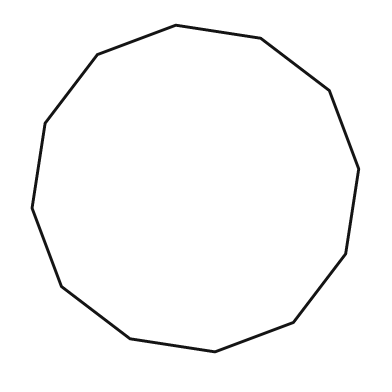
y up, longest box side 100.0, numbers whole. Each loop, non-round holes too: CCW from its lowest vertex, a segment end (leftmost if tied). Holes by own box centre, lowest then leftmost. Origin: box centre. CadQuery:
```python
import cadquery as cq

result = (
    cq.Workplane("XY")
    .moveTo(6.0, -50.0)
    .lineTo(30.0, -41.0)
    .lineTo(46.0, -20.0)
    .lineTo(50.0, 6.0)
    .lineTo(41.0, 30.0)
    .lineTo(20.0, 46.0)
    .lineTo(-6.0, 50.0)
    .lineTo(-30.0, 41.0)
    .lineTo(-46.0, 20.0)
    .lineTo(-50.0, -6.0)
    .lineTo(-41.0, -30.0)
    .lineTo(-20.0, -46.0)
    .close()
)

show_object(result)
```